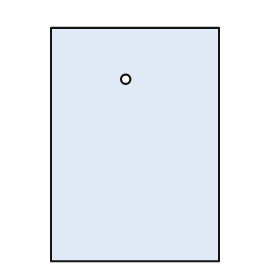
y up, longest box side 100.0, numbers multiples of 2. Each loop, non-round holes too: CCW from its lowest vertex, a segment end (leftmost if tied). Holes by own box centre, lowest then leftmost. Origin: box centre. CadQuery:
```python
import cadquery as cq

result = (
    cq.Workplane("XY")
    .moveTo(-36.0, -50.0)
    .lineTo(36.0, -50.0)
    .lineTo(36.0, 50.0)
    .lineTo(-36.0, 50.0)
    .close()
    .moveTo(-4.0, 28.0)
    .circle(2.0)
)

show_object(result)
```